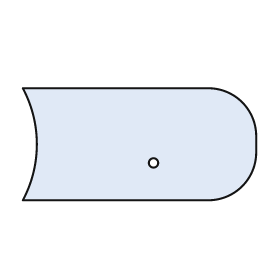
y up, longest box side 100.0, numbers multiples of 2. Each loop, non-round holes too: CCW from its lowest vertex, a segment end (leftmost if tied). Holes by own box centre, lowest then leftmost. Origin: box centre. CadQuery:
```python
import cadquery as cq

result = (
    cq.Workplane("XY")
    .moveTo(-50.0, -24.0)
    .lineTo(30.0, -24.0)
    .threePointArc((44.0, -18.0), (50.0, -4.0))
    .lineTo(50.0, 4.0)
    .threePointArc((44.0, 18.0), (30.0, 24.0))
    .lineTo(-50.0, 24.0)
    .threePointArc((-44.0, 0.0), (-50.0, -24.0))
    .close()
    .moveTo(6.0, -8.0)
    .circle(2.0)
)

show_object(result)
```